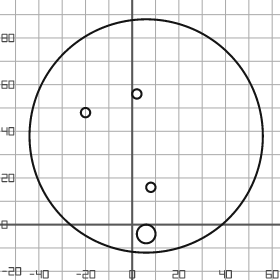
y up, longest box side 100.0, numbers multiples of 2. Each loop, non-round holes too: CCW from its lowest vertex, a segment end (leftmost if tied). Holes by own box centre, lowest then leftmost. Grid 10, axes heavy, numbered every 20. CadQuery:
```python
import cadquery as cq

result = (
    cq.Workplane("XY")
    .moveTo(6.0, 38.0)
    .circle(50.0)
    .moveTo(6.0, -4.0)
    .circle(4.0)
    .moveTo(8.0, 16.0)
    .circle(2.0)
    .moveTo(-20.0, 48.0)
    .circle(2.0)
    .moveTo(2.0, 56.0)
    .circle(2.0)
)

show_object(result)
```